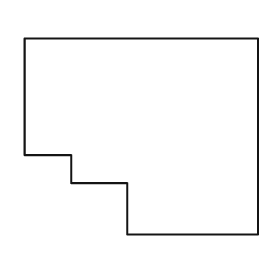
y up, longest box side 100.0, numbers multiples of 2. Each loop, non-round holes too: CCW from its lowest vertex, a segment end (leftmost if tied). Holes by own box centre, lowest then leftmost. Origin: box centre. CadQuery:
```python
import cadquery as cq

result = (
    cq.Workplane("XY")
    .moveTo(-6.0, -42.0)
    .lineTo(50.0, -42.0)
    .lineTo(50.0, 42.0)
    .lineTo(-50.0, 42.0)
    .lineTo(-50.0, -8.0)
    .lineTo(-30.0, -8.0)
    .lineTo(-30.0, -20.0)
    .lineTo(-6.0, -20.0)
    .close()
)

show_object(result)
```